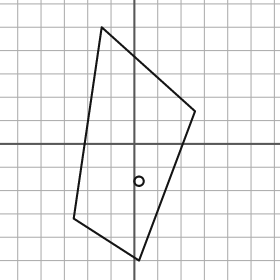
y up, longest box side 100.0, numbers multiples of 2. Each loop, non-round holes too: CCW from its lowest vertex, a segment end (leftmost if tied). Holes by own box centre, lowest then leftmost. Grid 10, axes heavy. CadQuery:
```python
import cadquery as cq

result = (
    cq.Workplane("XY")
    .moveTo(2.0, -50.0)
    .lineTo(26.0, 14.0)
    .lineTo(-14.0, 50.0)
    .lineTo(-26.0, -32.0)
    .close()
    .moveTo(2.0, -16.0)
    .circle(2.0)
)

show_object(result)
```